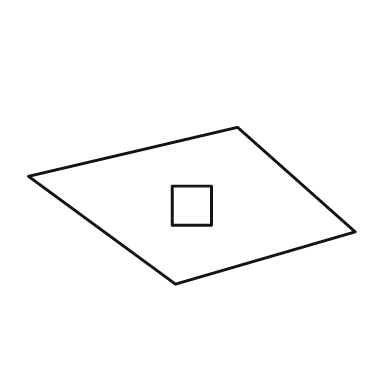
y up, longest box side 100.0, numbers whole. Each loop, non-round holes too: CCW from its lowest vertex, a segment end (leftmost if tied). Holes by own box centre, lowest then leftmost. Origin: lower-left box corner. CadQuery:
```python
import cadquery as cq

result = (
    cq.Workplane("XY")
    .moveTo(45.0, 0.0)
    .lineTo(100.0, 16.0)
    .lineTo(64.0, 48.0)
    .lineTo(0.0, 33.0)
    .close()
    .moveTo(44.0, 18.0)
    .lineTo(56.0, 18.0)
    .lineTo(56.0, 30.0)
    .lineTo(44.0, 30.0)
    .close()
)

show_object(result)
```